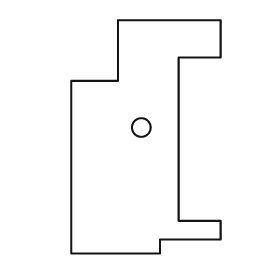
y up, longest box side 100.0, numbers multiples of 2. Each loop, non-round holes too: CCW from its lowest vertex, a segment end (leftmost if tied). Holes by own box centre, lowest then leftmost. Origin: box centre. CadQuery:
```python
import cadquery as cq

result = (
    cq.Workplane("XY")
    .moveTo(-32.0, -50.0)
    .lineTo(6.0, -50.0)
    .lineTo(6.0, -44.0)
    .lineTo(32.0, -44.0)
    .lineTo(32.0, -36.0)
    .lineTo(14.0, -36.0)
    .lineTo(14.0, 34.0)
    .lineTo(32.0, 34.0)
    .lineTo(32.0, 50.0)
    .lineTo(-12.0, 50.0)
    .lineTo(-12.0, 24.0)
    .lineTo(-32.0, 24.0)
    .close()
    .moveTo(-2.0, 4.0)
    .circle(4.0)
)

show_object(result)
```